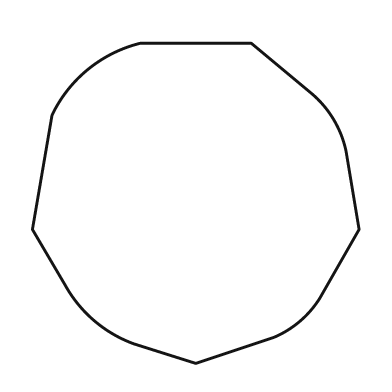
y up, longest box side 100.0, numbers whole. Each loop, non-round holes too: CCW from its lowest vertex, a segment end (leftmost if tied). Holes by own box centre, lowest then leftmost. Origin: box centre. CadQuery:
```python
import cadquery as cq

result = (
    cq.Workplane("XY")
    .moveTo(0.0, -49.0)
    .lineTo(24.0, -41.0)
    .threePointArc((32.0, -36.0), (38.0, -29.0))
    .lineTo(50.0, -8.0)
    .lineTo(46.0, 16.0)
    .threePointArc((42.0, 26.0), (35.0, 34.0))
    .lineTo(17.0, 49.0)
    .lineTo(-17.0, 49.0)
    .threePointArc((-33.0, 41.0), (-44.0, 27.0))
    .lineTo(-50.0, -8.0)
    .lineTo(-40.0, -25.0)
    .threePointArc((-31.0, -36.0), (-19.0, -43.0))
    .close()
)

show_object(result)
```